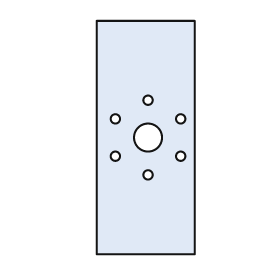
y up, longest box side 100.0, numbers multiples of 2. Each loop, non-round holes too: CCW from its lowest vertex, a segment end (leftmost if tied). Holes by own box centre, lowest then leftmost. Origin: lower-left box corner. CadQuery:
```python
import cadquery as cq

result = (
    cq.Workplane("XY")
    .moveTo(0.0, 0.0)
    .lineTo(42.0, 0.0)
    .lineTo(42.0, 100.0)
    .lineTo(0.0, 100.0)
    .close()
    .moveTo(22.0, 34.0)
    .circle(2.0)
    .moveTo(8.0, 42.0)
    .circle(2.0)
    .moveTo(36.0, 42.0)
    .circle(2.0)
    .moveTo(22.0, 50.0)
    .circle(6.0)
    .moveTo(8.0, 58.0)
    .circle(2.0)
    .moveTo(36.0, 58.0)
    .circle(2.0)
    .moveTo(22.0, 66.0)
    .circle(2.0)
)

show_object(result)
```